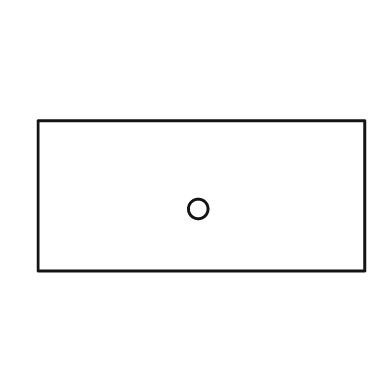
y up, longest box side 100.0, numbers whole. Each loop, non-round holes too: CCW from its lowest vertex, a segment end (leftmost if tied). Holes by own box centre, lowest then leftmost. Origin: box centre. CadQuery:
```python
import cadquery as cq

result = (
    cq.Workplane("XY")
    .moveTo(-50.0, -23.0)
    .lineTo(50.0, -23.0)
    .lineTo(50.0, 23.0)
    .lineTo(-50.0, 23.0)
    .close()
    .moveTo(-1.0, -4.0)
    .circle(3.0)
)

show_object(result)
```